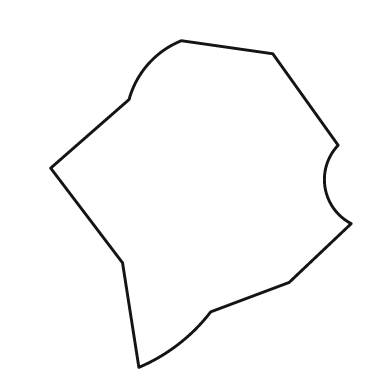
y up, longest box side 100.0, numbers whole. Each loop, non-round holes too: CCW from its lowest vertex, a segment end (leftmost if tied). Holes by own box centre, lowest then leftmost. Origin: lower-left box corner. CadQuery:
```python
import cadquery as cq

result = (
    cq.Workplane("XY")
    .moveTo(27.0, 0.0)
    .threePointArc((39.0, 7.0), (49.0, 17.0))
    .lineTo(73.0, 26.0)
    .lineTo(92.0, 44.0)
    .threePointArc((84.0, 55.0), (88.0, 68.0))
    .lineTo(68.0, 96.0)
    .lineTo(40.0, 100.0)
    .threePointArc((30.0, 93.0), (24.0, 82.0))
    .lineTo(0.0, 61.0)
    .lineTo(22.0, 32.0)
    .close()
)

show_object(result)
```